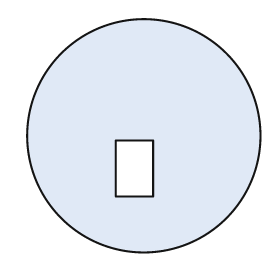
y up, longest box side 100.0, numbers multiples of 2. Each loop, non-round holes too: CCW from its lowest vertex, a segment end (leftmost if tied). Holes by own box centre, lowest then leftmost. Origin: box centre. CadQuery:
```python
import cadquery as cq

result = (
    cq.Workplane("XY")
    .moveTo(0.0, 0.0)
    .circle(50.0)
    .moveTo(-12.0, -26.0)
    .lineTo(4.0, -26.0)
    .lineTo(4.0, -2.0)
    .lineTo(-12.0, -2.0)
    .close()
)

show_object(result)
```